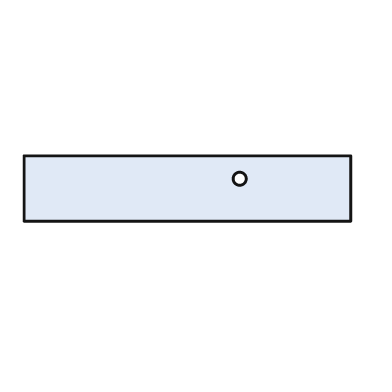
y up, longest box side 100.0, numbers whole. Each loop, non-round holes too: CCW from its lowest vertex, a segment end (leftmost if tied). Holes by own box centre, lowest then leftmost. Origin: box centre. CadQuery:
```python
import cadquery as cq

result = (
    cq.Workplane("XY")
    .moveTo(-50.0, -10.0)
    .lineTo(50.0, -10.0)
    .lineTo(50.0, 10.0)
    .lineTo(-50.0, 10.0)
    .close()
    .moveTo(16.0, 3.0)
    .circle(2.0)
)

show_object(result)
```